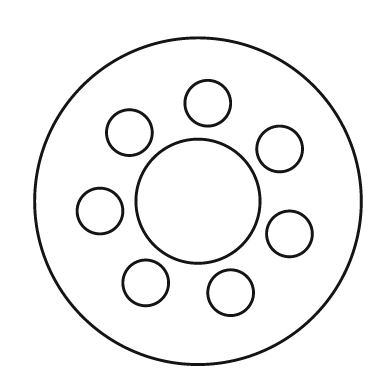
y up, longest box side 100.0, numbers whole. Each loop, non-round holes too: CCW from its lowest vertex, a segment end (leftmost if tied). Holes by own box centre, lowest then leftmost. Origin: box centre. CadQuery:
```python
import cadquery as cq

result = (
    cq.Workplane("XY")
    .moveTo(0.0, 0.0)
    .circle(50.0)
    .moveTo(10.0, -28.0)
    .circle(7.0)
    .moveTo(-16.0, -25.0)
    .circle(7.0)
    .moveTo(28.0, -10.0)
    .circle(7.0)
    .moveTo(-30.0, -3.0)
    .circle(7.0)
    .moveTo(0.0, 0.0)
    .circle(19.0)
    .moveTo(25.0, 16.0)
    .circle(7.0)
    .moveTo(-21.0, 21.0)
    .circle(7.0)
    .moveTo(3.0, 30.0)
    .circle(7.0)
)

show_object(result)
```